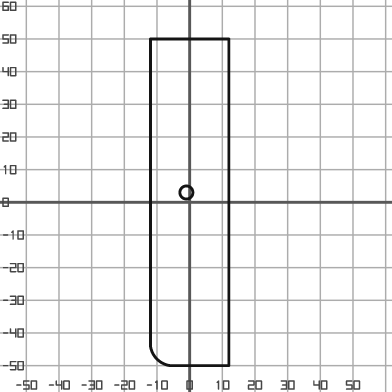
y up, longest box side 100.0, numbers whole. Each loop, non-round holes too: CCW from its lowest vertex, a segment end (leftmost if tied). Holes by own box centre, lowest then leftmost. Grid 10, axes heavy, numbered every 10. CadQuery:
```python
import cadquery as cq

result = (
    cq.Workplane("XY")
    .moveTo(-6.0, -50.0)
    .lineTo(12.0, -50.0)
    .lineTo(12.0, 50.0)
    .lineTo(-12.0, 50.0)
    .lineTo(-12.0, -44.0)
    .threePointArc((-10.0, -48.0), (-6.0, -50.0))
    .close()
    .moveTo(-1.0, 3.0)
    .circle(2.0)
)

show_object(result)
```